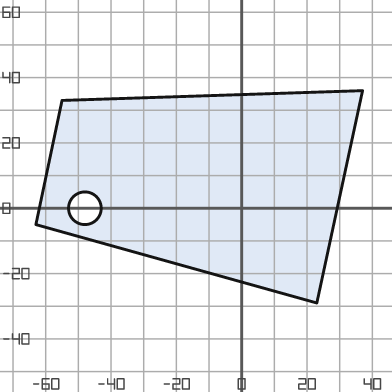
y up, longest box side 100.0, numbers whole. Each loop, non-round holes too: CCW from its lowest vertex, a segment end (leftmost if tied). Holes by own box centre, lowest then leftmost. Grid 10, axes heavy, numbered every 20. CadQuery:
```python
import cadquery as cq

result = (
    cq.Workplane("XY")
    .moveTo(23.0, -29.0)
    .lineTo(37.0, 36.0)
    .lineTo(-55.0, 33.0)
    .lineTo(-63.0, -5.0)
    .close()
    .moveTo(-48.0, 0.0)
    .circle(5.0)
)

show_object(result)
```